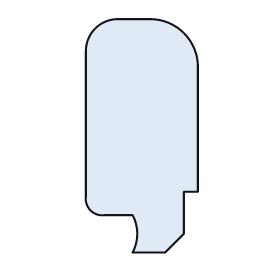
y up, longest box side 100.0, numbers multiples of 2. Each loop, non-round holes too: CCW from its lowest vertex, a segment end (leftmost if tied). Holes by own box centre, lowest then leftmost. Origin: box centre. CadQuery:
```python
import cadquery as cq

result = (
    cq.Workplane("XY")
    .moveTo(-4.0, -50.0)
    .lineTo(10.0, -50.0)
    .lineTo(18.0, -42.0)
    .lineTo(18.0, -24.0)
    .lineTo(24.0, -24.0)
    .lineTo(24.0, 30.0)
    .threePointArc((18.0, 44.0), (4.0, 50.0))
    .lineTo(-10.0, 50.0)
    .threePointArc((-20.0, 46.0), (-24.0, 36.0))
    .lineTo(-24.0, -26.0)
    .threePointArc((-22.0, -32.0), (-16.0, -34.0))
    .lineTo(-4.0, -34.0)
    .threePointArc((-2.0, -42.0), (-4.0, -50.0))
    .close()
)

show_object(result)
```